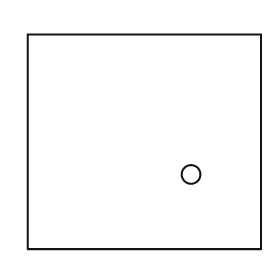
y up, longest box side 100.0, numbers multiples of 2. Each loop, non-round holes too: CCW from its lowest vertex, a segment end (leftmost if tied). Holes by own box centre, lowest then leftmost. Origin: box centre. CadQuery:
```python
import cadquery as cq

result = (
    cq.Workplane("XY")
    .moveTo(-50.0, -46.0)
    .lineTo(50.0, -46.0)
    .lineTo(50.0, 46.0)
    .lineTo(-50.0, 46.0)
    .close()
    .moveTo(20.0, -14.0)
    .circle(4.0)
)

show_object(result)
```